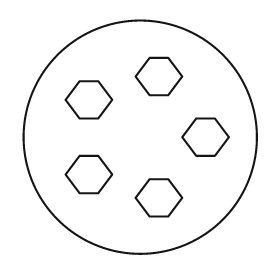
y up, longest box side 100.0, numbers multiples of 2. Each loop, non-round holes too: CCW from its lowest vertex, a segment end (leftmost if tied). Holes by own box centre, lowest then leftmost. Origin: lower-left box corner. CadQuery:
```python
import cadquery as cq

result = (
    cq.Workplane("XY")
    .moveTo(50.0, 50.0)
    .circle(50.0)
    .moveTo(54.0, 16.0)
    .lineTo(62.0, 16.0)
    .lineTo(68.0, 24.0)
    .lineTo(62.0, 32.0)
    .lineTo(54.0, 32.0)
    .lineTo(48.0, 24.0)
    .close()
    .moveTo(24.0, 26.0)
    .lineTo(32.0, 26.0)
    .lineTo(38.0, 34.0)
    .lineTo(32.0, 42.0)
    .lineTo(24.0, 42.0)
    .lineTo(18.0, 34.0)
    .close()
    .moveTo(74.0, 42.0)
    .lineTo(82.0, 42.0)
    .lineTo(88.0, 50.0)
    .lineTo(82.0, 58.0)
    .lineTo(74.0, 58.0)
    .lineTo(68.0, 50.0)
    .close()
    .moveTo(24.0, 58.0)
    .lineTo(32.0, 58.0)
    .lineTo(38.0, 66.0)
    .lineTo(32.0, 74.0)
    .lineTo(24.0, 74.0)
    .lineTo(18.0, 66.0)
    .close()
    .moveTo(54.0, 68.0)
    .lineTo(62.0, 68.0)
    .lineTo(68.0, 76.0)
    .lineTo(62.0, 84.0)
    .lineTo(54.0, 84.0)
    .lineTo(48.0, 76.0)
    .close()
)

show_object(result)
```